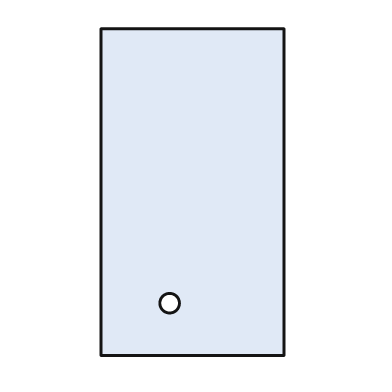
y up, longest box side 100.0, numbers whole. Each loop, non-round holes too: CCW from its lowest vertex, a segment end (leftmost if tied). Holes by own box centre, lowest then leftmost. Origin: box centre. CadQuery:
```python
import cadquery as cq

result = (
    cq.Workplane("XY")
    .moveTo(-28.0, -50.0)
    .lineTo(28.0, -50.0)
    .lineTo(28.0, 50.0)
    .lineTo(-28.0, 50.0)
    .close()
    .moveTo(-7.0, -34.0)
    .circle(3.0)
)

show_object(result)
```